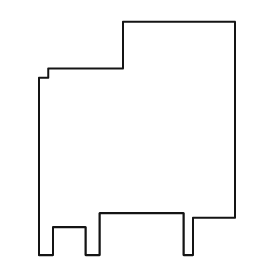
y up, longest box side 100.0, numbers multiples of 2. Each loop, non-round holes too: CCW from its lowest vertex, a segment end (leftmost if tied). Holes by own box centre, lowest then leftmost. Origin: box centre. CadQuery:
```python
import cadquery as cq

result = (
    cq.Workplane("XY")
    .moveTo(-42.0, -50.0)
    .lineTo(-36.0, -50.0)
    .lineTo(-36.0, -38.0)
    .lineTo(-22.0, -38.0)
    .lineTo(-22.0, -50.0)
    .lineTo(-16.0, -50.0)
    .lineTo(-16.0, -32.0)
    .lineTo(20.0, -32.0)
    .lineTo(20.0, -50.0)
    .lineTo(24.0, -50.0)
    .lineTo(24.0, -34.0)
    .lineTo(42.0, -34.0)
    .lineTo(42.0, 50.0)
    .lineTo(-6.0, 50.0)
    .lineTo(-6.0, 30.0)
    .lineTo(-38.0, 30.0)
    .lineTo(-38.0, 26.0)
    .lineTo(-42.0, 26.0)
    .close()
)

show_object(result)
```